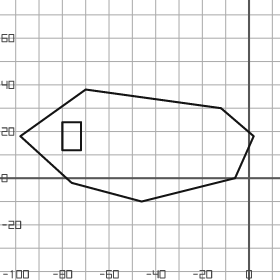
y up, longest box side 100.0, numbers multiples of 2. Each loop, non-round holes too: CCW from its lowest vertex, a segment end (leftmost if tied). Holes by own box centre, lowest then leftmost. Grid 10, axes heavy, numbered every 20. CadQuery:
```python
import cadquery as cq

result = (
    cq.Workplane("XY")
    .moveTo(-46.0, -10.0)
    .lineTo(-6.0, 0.0)
    .lineTo(2.0, 18.0)
    .lineTo(-12.0, 30.0)
    .lineTo(-70.0, 38.0)
    .lineTo(-98.0, 18.0)
    .lineTo(-76.0, -2.0)
    .close()
    .moveTo(-80.0, 12.0)
    .lineTo(-72.0, 12.0)
    .lineTo(-72.0, 24.0)
    .lineTo(-80.0, 24.0)
    .close()
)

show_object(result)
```